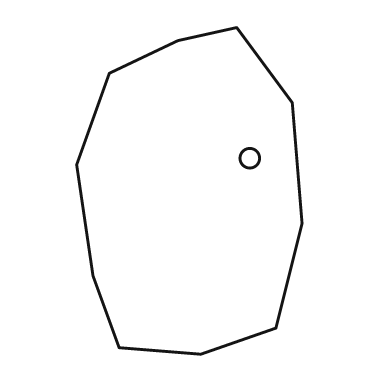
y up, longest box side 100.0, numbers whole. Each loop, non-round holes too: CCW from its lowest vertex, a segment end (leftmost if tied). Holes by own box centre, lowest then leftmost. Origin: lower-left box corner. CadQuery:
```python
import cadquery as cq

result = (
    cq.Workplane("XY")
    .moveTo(38.0, 0.0)
    .lineTo(61.0, 8.0)
    .lineTo(69.0, 40.0)
    .lineTo(66.0, 77.0)
    .lineTo(49.0, 100.0)
    .lineTo(31.0, 96.0)
    .lineTo(10.0, 86.0)
    .lineTo(0.0, 58.0)
    .lineTo(5.0, 24.0)
    .lineTo(13.0, 2.0)
    .close()
    .moveTo(53.0, 60.0)
    .circle(3.0)
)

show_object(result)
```